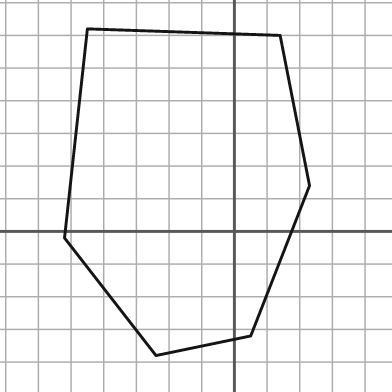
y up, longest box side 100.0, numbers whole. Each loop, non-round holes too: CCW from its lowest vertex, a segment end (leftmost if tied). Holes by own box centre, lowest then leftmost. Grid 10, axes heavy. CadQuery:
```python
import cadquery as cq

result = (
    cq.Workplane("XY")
    .moveTo(-24.0, -38.0)
    .lineTo(5.0, -32.0)
    .lineTo(23.0, 14.0)
    .lineTo(14.0, 60.0)
    .lineTo(-45.0, 62.0)
    .lineTo(-52.0, -2.0)
    .close()
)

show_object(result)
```